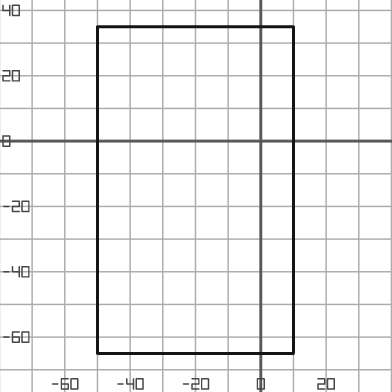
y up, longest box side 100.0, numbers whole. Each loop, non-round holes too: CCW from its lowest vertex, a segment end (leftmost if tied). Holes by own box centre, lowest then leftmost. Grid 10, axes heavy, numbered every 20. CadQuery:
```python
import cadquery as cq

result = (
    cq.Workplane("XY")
    .moveTo(-50.0, -65.0)
    .lineTo(10.0, -65.0)
    .lineTo(10.0, 35.0)
    .lineTo(-50.0, 35.0)
    .close()
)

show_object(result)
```